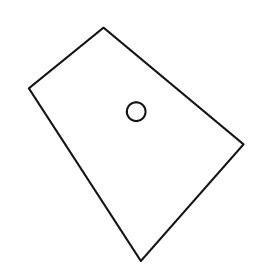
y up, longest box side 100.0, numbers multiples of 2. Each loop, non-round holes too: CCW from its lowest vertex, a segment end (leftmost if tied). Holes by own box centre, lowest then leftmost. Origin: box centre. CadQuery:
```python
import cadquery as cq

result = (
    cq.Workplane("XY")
    .moveTo(2.0, -50.0)
    .lineTo(46.0, 0.0)
    .lineTo(-14.0, 50.0)
    .lineTo(-46.0, 24.0)
    .close()
    .moveTo(0.0, 14.0)
    .circle(4.0)
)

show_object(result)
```